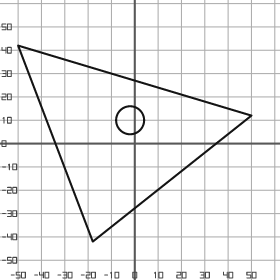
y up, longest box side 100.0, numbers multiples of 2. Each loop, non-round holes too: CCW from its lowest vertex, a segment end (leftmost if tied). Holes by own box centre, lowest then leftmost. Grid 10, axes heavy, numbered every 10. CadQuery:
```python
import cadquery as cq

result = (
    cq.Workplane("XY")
    .moveTo(-18.0, -42.0)
    .lineTo(50.0, 12.0)
    .lineTo(-50.0, 42.0)
    .close()
    .moveTo(-2.0, 10.0)
    .circle(6.0)
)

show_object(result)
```